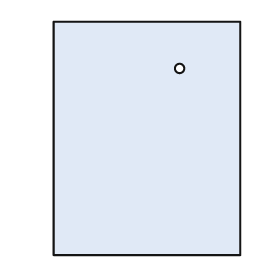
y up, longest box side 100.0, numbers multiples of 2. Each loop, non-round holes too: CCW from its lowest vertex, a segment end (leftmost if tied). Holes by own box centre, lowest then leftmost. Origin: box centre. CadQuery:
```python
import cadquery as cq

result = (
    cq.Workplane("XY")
    .moveTo(-40.0, -50.0)
    .lineTo(40.0, -50.0)
    .lineTo(40.0, 50.0)
    .lineTo(-40.0, 50.0)
    .close()
    .moveTo(14.0, 30.0)
    .circle(2.0)
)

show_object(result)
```